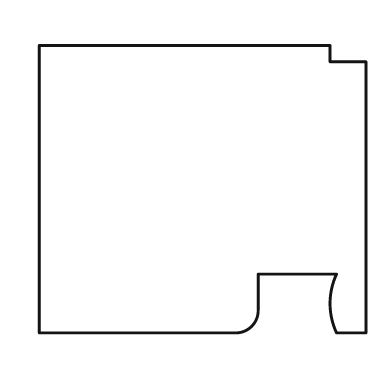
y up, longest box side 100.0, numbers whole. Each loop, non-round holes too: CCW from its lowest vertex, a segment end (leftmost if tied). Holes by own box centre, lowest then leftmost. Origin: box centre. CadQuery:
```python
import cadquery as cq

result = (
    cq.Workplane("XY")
    .moveTo(-50.0, -44.0)
    .lineTo(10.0, -44.0)
    .threePointArc((15.0, -42.0), (17.0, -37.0))
    .lineTo(17.0, -26.0)
    .lineTo(41.0, -26.0)
    .threePointArc((39.0, -35.0), (41.0, -44.0))
    .lineTo(50.0, -44.0)
    .lineTo(50.0, 39.0)
    .lineTo(39.0, 39.0)
    .lineTo(39.0, 44.0)
    .lineTo(-50.0, 44.0)
    .close()
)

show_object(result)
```